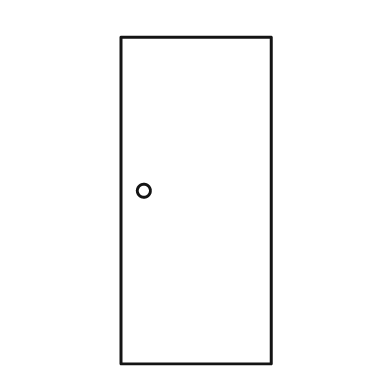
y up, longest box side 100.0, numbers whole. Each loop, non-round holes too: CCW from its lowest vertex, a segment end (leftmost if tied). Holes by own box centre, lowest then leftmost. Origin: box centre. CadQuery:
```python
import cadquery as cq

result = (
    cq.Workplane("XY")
    .moveTo(-23.0, -50.0)
    .lineTo(23.0, -50.0)
    .lineTo(23.0, 50.0)
    .lineTo(-23.0, 50.0)
    .close()
    .moveTo(-16.0, 3.0)
    .circle(2.0)
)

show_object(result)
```